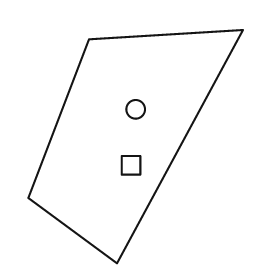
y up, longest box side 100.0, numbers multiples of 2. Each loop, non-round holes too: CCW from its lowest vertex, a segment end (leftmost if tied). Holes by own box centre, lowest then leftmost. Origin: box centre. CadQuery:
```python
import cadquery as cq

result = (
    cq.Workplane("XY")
    .moveTo(-8.0, -50.0)
    .lineTo(46.0, 50.0)
    .lineTo(-20.0, 46.0)
    .lineTo(-46.0, -22.0)
    .close()
    .moveTo(-6.0, -12.0)
    .lineTo(2.0, -12.0)
    .lineTo(2.0, -4.0)
    .lineTo(-6.0, -4.0)
    .close()
    .moveTo(0.0, 16.0)
    .circle(4.0)
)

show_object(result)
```